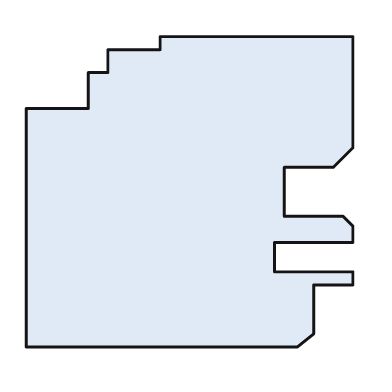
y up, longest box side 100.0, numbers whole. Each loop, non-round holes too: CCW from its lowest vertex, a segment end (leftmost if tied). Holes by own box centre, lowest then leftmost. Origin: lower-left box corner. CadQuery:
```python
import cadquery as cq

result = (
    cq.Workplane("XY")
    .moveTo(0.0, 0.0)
    .lineTo(83.0, 0.0)
    .lineTo(88.0, 4.0)
    .lineTo(88.0, 19.0)
    .lineTo(100.0, 19.0)
    .lineTo(100.0, 23.0)
    .lineTo(76.0, 23.0)
    .lineTo(76.0, 32.0)
    .lineTo(100.0, 32.0)
    .lineTo(100.0, 37.0)
    .lineTo(97.0, 40.0)
    .lineTo(79.0, 40.0)
    .lineTo(79.0, 55.0)
    .lineTo(94.0, 55.0)
    .lineTo(100.0, 61.0)
    .lineTo(100.0, 95.0)
    .lineTo(41.0, 95.0)
    .lineTo(41.0, 91.0)
    .lineTo(25.0, 91.0)
    .lineTo(25.0, 84.0)
    .lineTo(19.0, 84.0)
    .lineTo(19.0, 73.0)
    .lineTo(0.0, 73.0)
    .close()
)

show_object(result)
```